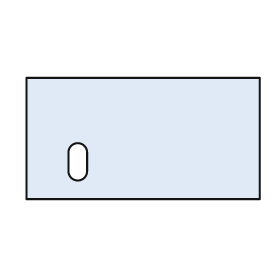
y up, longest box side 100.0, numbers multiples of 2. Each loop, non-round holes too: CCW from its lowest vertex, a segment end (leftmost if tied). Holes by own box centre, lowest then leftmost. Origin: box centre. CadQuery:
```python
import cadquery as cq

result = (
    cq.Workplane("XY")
    .moveTo(-50.0, -26.0)
    .lineTo(50.0, -26.0)
    .lineTo(50.0, 26.0)
    .lineTo(-50.0, 26.0)
    .close()
    .moveTo(-32.0, -14.0)
    .threePointArc((-28.0, -18.0), (-24.0, -14.0))
    .lineTo(-24.0, -6.0)
    .threePointArc((-28.0, -2.0), (-32.0, -6.0))
    .close()
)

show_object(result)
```